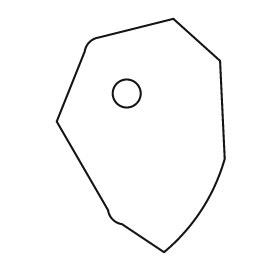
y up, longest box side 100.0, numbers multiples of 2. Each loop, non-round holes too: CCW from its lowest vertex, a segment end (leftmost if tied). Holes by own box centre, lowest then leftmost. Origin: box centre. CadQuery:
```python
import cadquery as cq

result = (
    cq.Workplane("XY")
    .moveTo(10.0, -50.0)
    .threePointArc((26.0, -32.0), (36.0, -10.0))
    .lineTo(34.0, 32.0)
    .lineTo(14.0, 50.0)
    .lineTo(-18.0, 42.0)
    .threePointArc((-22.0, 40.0), (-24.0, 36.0))
    .lineTo(-36.0, 6.0)
    .lineTo(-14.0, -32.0)
    .threePointArc((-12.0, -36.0), (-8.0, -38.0))
    .close()
    .moveTo(-6.0, 18.0)
    .circle(6.0)
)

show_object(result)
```